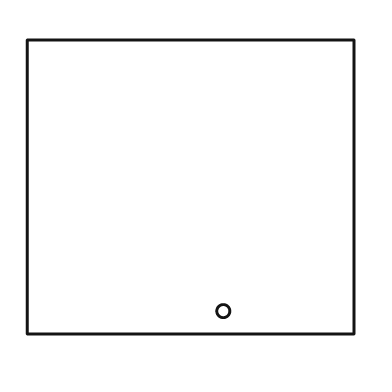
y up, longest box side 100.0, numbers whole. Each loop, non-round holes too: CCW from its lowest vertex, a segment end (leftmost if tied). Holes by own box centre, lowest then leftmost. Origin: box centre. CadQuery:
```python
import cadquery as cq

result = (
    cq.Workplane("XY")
    .moveTo(-50.0, -45.0)
    .lineTo(50.0, -45.0)
    .lineTo(50.0, 45.0)
    .lineTo(-50.0, 45.0)
    .close()
    .moveTo(10.0, -38.0)
    .circle(2.0)
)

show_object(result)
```